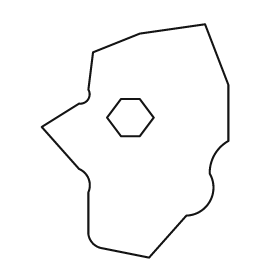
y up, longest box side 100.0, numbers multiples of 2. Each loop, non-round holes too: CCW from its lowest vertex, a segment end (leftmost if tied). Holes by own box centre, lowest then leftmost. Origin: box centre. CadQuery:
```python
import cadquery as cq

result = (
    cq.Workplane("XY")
    .moveTo(6.0, -50.0)
    .lineTo(22.0, -32.0)
    .threePointArc((32.0, -26.0), (32.0, -14.0))
    .threePointArc((34.0, -6.0), (40.0, 0.0))
    .lineTo(40.0, 24.0)
    .lineTo(30.0, 50.0)
    .lineTo(2.0, 46.0)
    .lineTo(-18.0, 38.0)
    .lineTo(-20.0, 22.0)
    .threePointArc((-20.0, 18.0), (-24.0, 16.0))
    .lineTo(-40.0, 6.0)
    .lineTo(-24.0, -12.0)
    .threePointArc((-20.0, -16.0), (-20.0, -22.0))
    .lineTo(-20.0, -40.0)
    .threePointArc((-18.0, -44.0), (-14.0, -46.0))
    .close()
    .moveTo(-6.0, 2.0)
    .lineTo(2.0, 2.0)
    .lineTo(8.0, 10.0)
    .lineTo(2.0, 18.0)
    .lineTo(-6.0, 18.0)
    .lineTo(-12.0, 10.0)
    .close()
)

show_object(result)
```